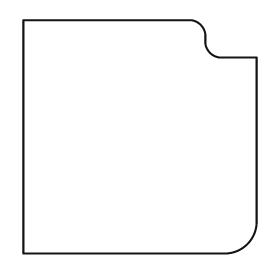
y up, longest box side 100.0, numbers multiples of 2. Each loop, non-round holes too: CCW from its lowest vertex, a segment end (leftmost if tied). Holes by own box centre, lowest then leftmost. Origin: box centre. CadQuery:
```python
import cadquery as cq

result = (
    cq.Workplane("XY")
    .moveTo(-50.0, -50.0)
    .lineTo(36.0, -50.0)
    .threePointArc((46.0, -46.0), (50.0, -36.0))
    .lineTo(50.0, 34.0)
    .lineTo(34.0, 34.0)
    .threePointArc((30.0, 36.0), (28.0, 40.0))
    .lineTo(28.0, 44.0)
    .threePointArc((26.0, 48.0), (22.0, 50.0))
    .lineTo(-50.0, 50.0)
    .close()
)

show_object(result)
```